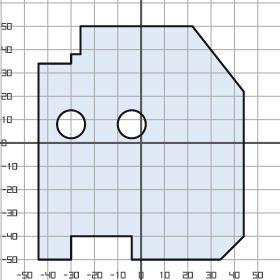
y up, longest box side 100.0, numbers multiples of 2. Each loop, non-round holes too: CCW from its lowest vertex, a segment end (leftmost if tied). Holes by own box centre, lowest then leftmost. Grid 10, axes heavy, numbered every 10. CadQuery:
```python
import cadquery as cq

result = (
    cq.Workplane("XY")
    .moveTo(-44.0, -50.0)
    .lineTo(-30.0, -50.0)
    .lineTo(-30.0, -40.0)
    .lineTo(-4.0, -40.0)
    .lineTo(-4.0, -50.0)
    .lineTo(34.0, -50.0)
    .lineTo(44.0, -40.0)
    .lineTo(44.0, 22.0)
    .lineTo(22.0, 50.0)
    .lineTo(-26.0, 50.0)
    .lineTo(-26.0, 38.0)
    .lineTo(-30.0, 38.0)
    .lineTo(-30.0, 34.0)
    .lineTo(-44.0, 34.0)
    .close()
    .moveTo(-30.0, 8.0)
    .circle(6.0)
    .moveTo(-4.0, 8.0)
    .circle(6.0)
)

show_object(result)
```